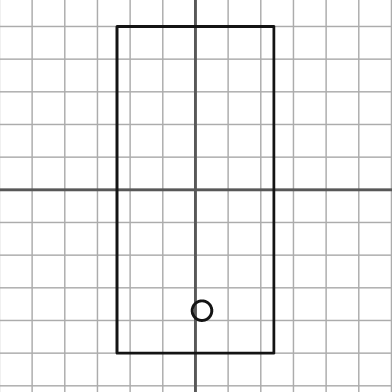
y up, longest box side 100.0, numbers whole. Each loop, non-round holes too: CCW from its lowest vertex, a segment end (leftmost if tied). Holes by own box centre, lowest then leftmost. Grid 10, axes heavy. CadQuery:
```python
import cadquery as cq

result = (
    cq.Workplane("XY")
    .moveTo(-24.0, -50.0)
    .lineTo(24.0, -50.0)
    .lineTo(24.0, 50.0)
    .lineTo(-24.0, 50.0)
    .close()
    .moveTo(2.0, -37.0)
    .circle(3.0)
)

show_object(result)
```